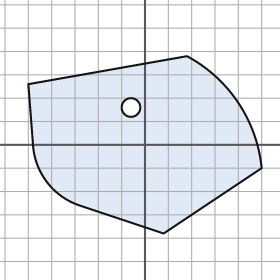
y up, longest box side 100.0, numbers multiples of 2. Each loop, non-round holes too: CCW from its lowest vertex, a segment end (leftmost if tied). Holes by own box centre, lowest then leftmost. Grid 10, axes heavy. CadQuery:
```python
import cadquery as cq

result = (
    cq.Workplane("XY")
    .moveTo(8.0, -38.0)
    .lineTo(50.0, -10.0)
    .threePointArc((40.0, 18.0), (18.0, 38.0))
    .lineTo(-50.0, 26.0)
    .lineTo(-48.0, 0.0)
    .threePointArc((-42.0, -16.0), (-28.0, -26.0))
    .close()
    .moveTo(-6.0, 16.0)
    .circle(4.0)
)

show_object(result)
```